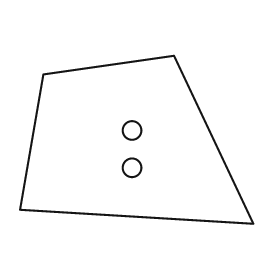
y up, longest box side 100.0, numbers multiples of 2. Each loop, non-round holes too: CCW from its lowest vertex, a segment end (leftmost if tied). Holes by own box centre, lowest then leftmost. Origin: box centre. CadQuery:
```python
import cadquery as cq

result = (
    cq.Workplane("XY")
    .moveTo(50.0, -36.0)
    .lineTo(16.0, 36.0)
    .lineTo(-40.0, 28.0)
    .lineTo(-50.0, -30.0)
    .close()
    .moveTo(-2.0, -12.0)
    .circle(4.0)
    .moveTo(-2.0, 4.0)
    .circle(4.0)
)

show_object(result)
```